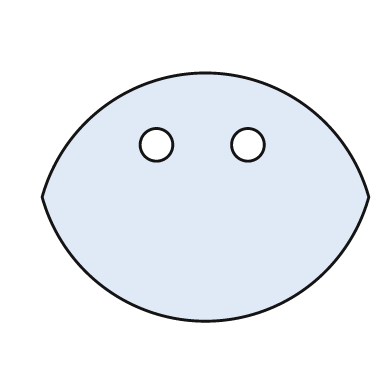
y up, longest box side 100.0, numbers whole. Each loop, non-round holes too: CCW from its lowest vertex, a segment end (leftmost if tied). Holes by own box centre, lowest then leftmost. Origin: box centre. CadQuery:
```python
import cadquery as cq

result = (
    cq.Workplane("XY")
    .moveTo(-50.0, 0.0)
    .threePointArc((0.0, -38.0), (50.0, 0.0))
    .threePointArc((0.0, 38.0), (-50.0, 0.0))
    .close()
    .moveTo(-15.0, 16.0)
    .circle(5.0)
    .moveTo(13.0, 16.0)
    .circle(5.0)
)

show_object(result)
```